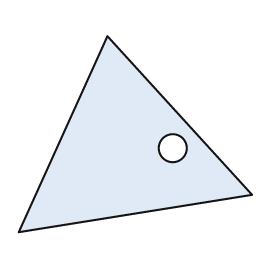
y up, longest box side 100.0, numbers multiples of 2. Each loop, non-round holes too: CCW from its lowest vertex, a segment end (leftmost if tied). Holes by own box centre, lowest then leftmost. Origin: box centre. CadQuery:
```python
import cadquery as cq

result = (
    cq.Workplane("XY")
    .moveTo(-50.0, -42.0)
    .lineTo(50.0, -26.0)
    .lineTo(-12.0, 42.0)
    .close()
    .moveTo(16.0, -6.0)
    .circle(6.0)
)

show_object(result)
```